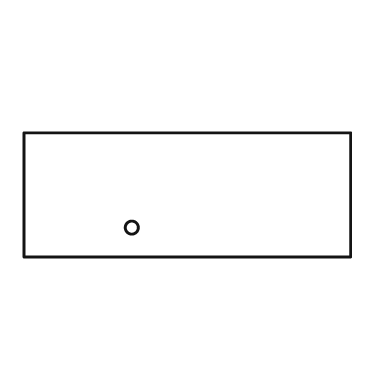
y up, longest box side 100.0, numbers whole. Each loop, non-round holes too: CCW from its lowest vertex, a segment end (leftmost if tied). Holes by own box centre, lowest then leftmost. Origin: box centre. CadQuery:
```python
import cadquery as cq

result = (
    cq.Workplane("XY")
    .moveTo(-50.0, -19.0)
    .lineTo(50.0, -19.0)
    .lineTo(50.0, 19.0)
    .lineTo(-50.0, 19.0)
    .close()
    .moveTo(-17.0, -10.0)
    .circle(2.0)
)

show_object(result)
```